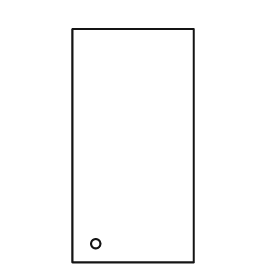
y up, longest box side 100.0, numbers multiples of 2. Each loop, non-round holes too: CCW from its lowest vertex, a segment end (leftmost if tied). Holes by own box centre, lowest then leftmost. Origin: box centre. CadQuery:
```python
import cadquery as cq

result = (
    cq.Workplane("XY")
    .moveTo(-26.0, -50.0)
    .lineTo(26.0, -50.0)
    .lineTo(26.0, 50.0)
    .lineTo(-26.0, 50.0)
    .close()
    .moveTo(-16.0, -42.0)
    .circle(2.0)
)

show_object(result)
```